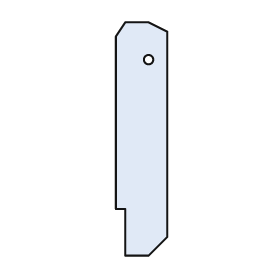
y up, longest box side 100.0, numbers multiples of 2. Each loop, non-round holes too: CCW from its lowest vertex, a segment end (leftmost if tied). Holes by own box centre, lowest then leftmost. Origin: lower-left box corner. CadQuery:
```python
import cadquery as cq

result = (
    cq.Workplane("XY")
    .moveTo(4.0, 0.0)
    .lineTo(14.0, 0.0)
    .lineTo(22.0, 8.0)
    .lineTo(22.0, 96.0)
    .lineTo(14.0, 100.0)
    .lineTo(4.0, 100.0)
    .lineTo(0.0, 94.0)
    .lineTo(0.0, 20.0)
    .lineTo(4.0, 20.0)
    .close()
    .moveTo(14.0, 84.0)
    .circle(2.0)
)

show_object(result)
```